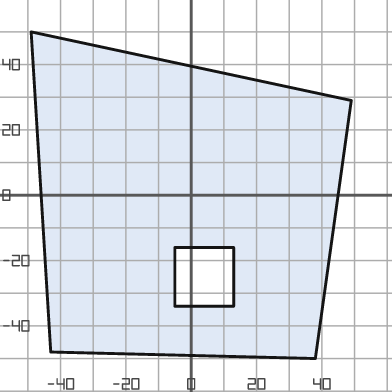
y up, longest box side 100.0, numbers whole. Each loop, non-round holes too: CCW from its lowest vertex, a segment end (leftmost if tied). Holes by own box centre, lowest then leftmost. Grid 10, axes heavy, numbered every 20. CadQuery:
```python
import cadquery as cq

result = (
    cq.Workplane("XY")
    .moveTo(38.0, -50.0)
    .lineTo(49.0, 29.0)
    .lineTo(-49.0, 50.0)
    .lineTo(-43.0, -48.0)
    .close()
    .moveTo(-5.0, -34.0)
    .lineTo(13.0, -34.0)
    .lineTo(13.0, -16.0)
    .lineTo(-5.0, -16.0)
    .close()
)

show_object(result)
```